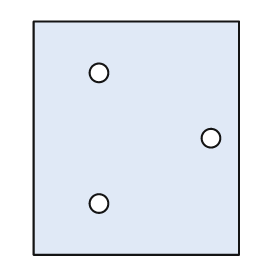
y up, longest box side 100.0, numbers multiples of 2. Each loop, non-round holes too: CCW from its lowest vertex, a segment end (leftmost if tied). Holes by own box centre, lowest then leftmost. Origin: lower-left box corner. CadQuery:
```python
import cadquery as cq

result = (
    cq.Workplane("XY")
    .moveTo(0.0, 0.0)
    .lineTo(88.0, 0.0)
    .lineTo(88.0, 100.0)
    .lineTo(0.0, 100.0)
    .close()
    .moveTo(28.0, 22.0)
    .circle(4.0)
    .moveTo(76.0, 50.0)
    .circle(4.0)
    .moveTo(28.0, 78.0)
    .circle(4.0)
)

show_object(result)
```